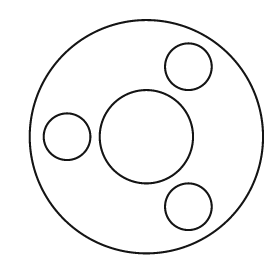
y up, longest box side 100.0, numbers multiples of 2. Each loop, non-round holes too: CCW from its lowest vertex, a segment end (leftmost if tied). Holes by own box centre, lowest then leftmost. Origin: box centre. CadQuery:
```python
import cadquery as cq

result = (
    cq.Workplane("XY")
    .moveTo(0.0, 0.0)
    .circle(50.0)
    .moveTo(18.0, -30.0)
    .circle(10.0)
    .moveTo(-34.0, 0.0)
    .circle(10.0)
    .moveTo(0.0, 0.0)
    .circle(20.0)
    .moveTo(18.0, 30.0)
    .circle(10.0)
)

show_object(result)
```